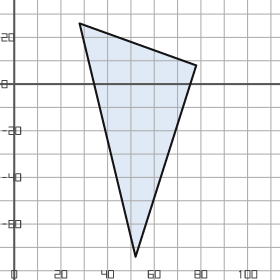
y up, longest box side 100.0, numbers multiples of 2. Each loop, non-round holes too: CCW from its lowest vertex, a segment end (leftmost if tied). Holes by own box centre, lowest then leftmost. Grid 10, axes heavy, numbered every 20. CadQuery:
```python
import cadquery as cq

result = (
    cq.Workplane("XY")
    .moveTo(52.0, -74.0)
    .lineTo(78.0, 8.0)
    .lineTo(28.0, 26.0)
    .close()
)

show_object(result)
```